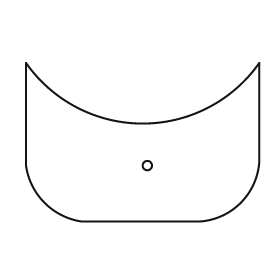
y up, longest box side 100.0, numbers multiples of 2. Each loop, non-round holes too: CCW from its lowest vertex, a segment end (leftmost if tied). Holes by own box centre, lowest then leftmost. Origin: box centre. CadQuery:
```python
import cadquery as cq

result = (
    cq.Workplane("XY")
    .moveTo(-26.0, -34.0)
    .lineTo(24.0, -34.0)
    .threePointArc((42.0, -26.0), (50.0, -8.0))
    .lineTo(50.0, 34.0)
    .threePointArc((0.0, 8.0), (-50.0, 34.0))
    .lineTo(-50.0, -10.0)
    .threePointArc((-42.0, -26.0), (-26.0, -34.0))
    .close()
    .moveTo(2.0, -10.0)
    .circle(2.0)
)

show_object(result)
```